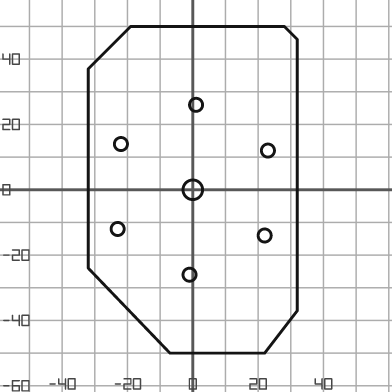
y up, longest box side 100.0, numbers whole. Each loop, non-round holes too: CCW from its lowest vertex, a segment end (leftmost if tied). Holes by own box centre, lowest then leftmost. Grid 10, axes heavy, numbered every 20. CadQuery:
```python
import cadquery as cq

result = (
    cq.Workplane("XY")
    .moveTo(-7.0, -50.0)
    .lineTo(22.0, -50.0)
    .lineTo(32.0, -37.0)
    .lineTo(32.0, 46.0)
    .lineTo(28.0, 50.0)
    .lineTo(-19.0, 50.0)
    .lineTo(-32.0, 37.0)
    .lineTo(-32.0, -24.0)
    .close()
    .moveTo(-1.0, -26.0)
    .circle(2.0)
    .moveTo(22.0, -14.0)
    .circle(2.0)
    .moveTo(-23.0, -12.0)
    .circle(2.0)
    .moveTo(0.0, 0.0)
    .circle(3.0)
    .moveTo(23.0, 12.0)
    .circle(2.0)
    .moveTo(-22.0, 14.0)
    .circle(2.0)
    .moveTo(1.0, 26.0)
    .circle(2.0)
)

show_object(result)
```